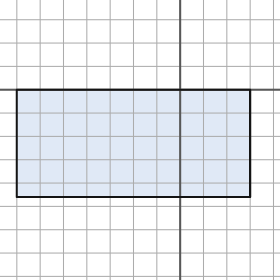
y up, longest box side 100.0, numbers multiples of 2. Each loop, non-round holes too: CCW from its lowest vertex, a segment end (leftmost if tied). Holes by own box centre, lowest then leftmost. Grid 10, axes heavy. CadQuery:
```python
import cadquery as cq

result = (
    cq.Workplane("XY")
    .moveTo(-70.0, -46.0)
    .lineTo(30.0, -46.0)
    .lineTo(30.0, 0.0)
    .lineTo(-70.0, 0.0)
    .close()
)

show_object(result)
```